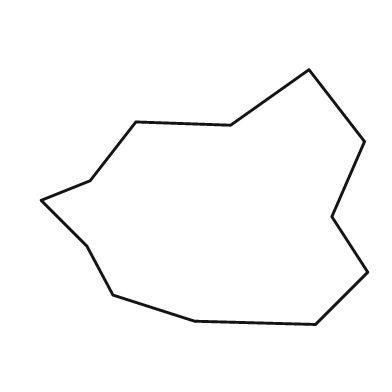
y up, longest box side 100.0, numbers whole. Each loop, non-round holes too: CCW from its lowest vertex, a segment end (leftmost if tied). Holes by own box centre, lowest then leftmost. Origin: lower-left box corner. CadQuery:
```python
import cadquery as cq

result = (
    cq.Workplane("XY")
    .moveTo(84.0, 0.0)
    .lineTo(100.0, 16.0)
    .lineTo(89.0, 33.0)
    .lineTo(99.0, 56.0)
    .lineTo(82.0, 78.0)
    .lineTo(58.0, 61.0)
    .lineTo(29.0, 62.0)
    .lineTo(15.0, 44.0)
    .lineTo(0.0, 38.0)
    .lineTo(14.0, 24.0)
    .lineTo(22.0, 9.0)
    .lineTo(47.0, 1.0)
    .close()
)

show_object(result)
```